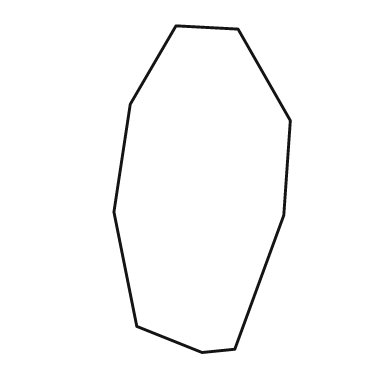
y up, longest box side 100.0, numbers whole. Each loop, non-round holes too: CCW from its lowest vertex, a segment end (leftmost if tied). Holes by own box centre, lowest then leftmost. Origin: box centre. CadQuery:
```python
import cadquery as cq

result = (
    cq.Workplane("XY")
    .moveTo(0.0, -50.0)
    .lineTo(10.0, -49.0)
    .lineTo(25.0, -8.0)
    .lineTo(27.0, 21.0)
    .lineTo(11.0, 49.0)
    .lineTo(-8.0, 50.0)
    .lineTo(-22.0, 26.0)
    .lineTo(-27.0, -7.0)
    .lineTo(-20.0, -42.0)
    .close()
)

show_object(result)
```